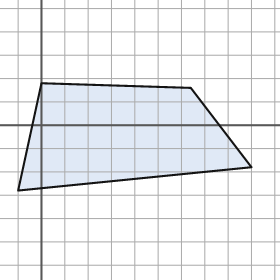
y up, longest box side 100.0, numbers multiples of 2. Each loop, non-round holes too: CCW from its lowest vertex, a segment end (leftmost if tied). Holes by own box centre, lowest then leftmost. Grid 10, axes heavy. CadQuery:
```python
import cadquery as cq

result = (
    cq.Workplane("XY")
    .moveTo(-10.0, -28.0)
    .lineTo(90.0, -18.0)
    .lineTo(64.0, 16.0)
    .lineTo(0.0, 18.0)
    .close()
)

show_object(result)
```